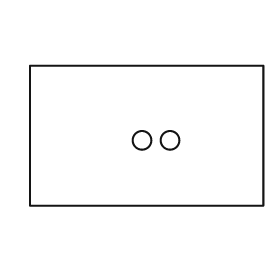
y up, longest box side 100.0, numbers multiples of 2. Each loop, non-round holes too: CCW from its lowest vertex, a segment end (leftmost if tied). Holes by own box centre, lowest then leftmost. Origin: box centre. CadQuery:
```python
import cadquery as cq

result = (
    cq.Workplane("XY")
    .moveTo(-50.0, -30.0)
    .lineTo(50.0, -30.0)
    .lineTo(50.0, 30.0)
    .lineTo(-50.0, 30.0)
    .close()
    .moveTo(-2.0, -2.0)
    .circle(4.0)
    .moveTo(10.0, -2.0)
    .circle(4.0)
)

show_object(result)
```